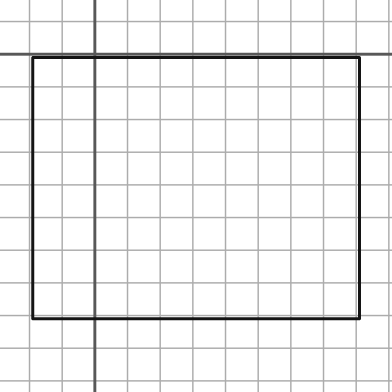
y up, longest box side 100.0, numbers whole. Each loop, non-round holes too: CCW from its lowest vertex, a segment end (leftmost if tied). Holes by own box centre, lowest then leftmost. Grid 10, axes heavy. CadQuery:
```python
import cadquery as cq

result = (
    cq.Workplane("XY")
    .moveTo(-19.0, -81.0)
    .lineTo(81.0, -81.0)
    .lineTo(81.0, -1.0)
    .lineTo(-19.0, -1.0)
    .close()
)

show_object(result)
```